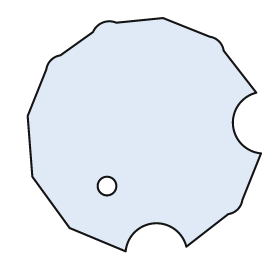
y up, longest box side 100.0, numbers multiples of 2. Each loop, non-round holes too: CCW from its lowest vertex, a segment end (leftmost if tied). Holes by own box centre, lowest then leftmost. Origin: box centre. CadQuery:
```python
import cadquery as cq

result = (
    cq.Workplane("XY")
    .moveTo(-8.0, -50.0)
    .threePointArc((4.0, -38.0), (18.0, -48.0))
    .lineTo(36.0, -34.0)
    .threePointArc((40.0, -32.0), (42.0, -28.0))
    .lineTo(50.0, -8.0)
    .threePointArc((38.0, 4.0), (48.0, 18.0))
    .lineTo(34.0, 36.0)
    .threePointArc((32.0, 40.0), (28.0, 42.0))
    .lineTo(8.0, 50.0)
    .lineTo(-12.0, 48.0)
    .threePointArc((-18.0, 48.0), (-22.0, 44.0))
    .lineTo(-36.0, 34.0)
    .threePointArc((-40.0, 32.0), (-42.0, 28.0))
    .lineTo(-50.0, 8.0)
    .lineTo(-48.0, -18.0)
    .lineTo(-32.0, -40.0)
    .close()
    .moveTo(-16.0, -22.0)
    .circle(4.0)
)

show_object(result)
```